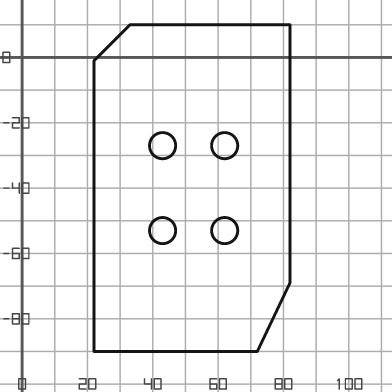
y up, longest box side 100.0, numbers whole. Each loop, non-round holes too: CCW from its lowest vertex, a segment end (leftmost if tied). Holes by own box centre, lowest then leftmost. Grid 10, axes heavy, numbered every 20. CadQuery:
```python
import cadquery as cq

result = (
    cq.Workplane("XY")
    .moveTo(22.0, -90.0)
    .lineTo(72.0, -90.0)
    .lineTo(82.0, -69.0)
    .lineTo(82.0, 10.0)
    .lineTo(33.0, 10.0)
    .lineTo(22.0, -1.0)
    .close()
    .moveTo(43.0, -53.0)
    .circle(4.0)
    .moveTo(62.0, -53.0)
    .circle(4.0)
    .moveTo(43.0, -27.0)
    .circle(4.0)
    .moveTo(62.0, -27.0)
    .circle(4.0)
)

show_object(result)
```